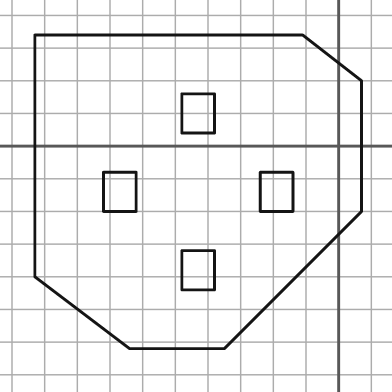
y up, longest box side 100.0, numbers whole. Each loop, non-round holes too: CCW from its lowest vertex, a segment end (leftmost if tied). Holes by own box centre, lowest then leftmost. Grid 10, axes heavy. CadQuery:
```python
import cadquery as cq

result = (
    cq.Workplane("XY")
    .moveTo(-64.0, -62.0)
    .lineTo(-35.0, -62.0)
    .lineTo(7.0, -20.0)
    .lineTo(7.0, 20.0)
    .lineTo(-11.0, 34.0)
    .lineTo(-93.0, 34.0)
    .lineTo(-93.0, -40.0)
    .close()
    .moveTo(-48.0, -44.0)
    .lineTo(-38.0, -44.0)
    .lineTo(-38.0, -32.0)
    .lineTo(-48.0, -32.0)
    .close()
    .moveTo(-72.0, -20.0)
    .lineTo(-62.0, -20.0)
    .lineTo(-62.0, -8.0)
    .lineTo(-72.0, -8.0)
    .close()
    .moveTo(-24.0, -20.0)
    .lineTo(-14.0, -20.0)
    .lineTo(-14.0, -8.0)
    .lineTo(-24.0, -8.0)
    .close()
    .moveTo(-48.0, 4.0)
    .lineTo(-38.0, 4.0)
    .lineTo(-38.0, 16.0)
    .lineTo(-48.0, 16.0)
    .close()
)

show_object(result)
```